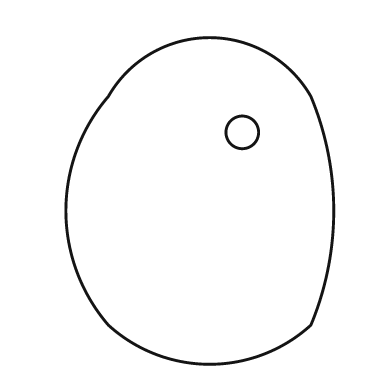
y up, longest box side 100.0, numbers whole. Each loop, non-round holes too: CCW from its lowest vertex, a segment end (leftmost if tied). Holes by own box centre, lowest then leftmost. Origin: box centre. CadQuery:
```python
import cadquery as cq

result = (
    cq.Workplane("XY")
    .moveTo(-28.0, -38.0)
    .threePointArc((3.0, -50.0), (34.0, -38.0))
    .threePointArc((41.0, -3.0), (34.0, 32.0))
    .threePointArc((3.0, 50.0), (-28.0, 32.0))
    .threePointArc((-41.0, -3.0), (-28.0, -38.0))
    .close()
    .moveTo(13.0, 21.0)
    .circle(5.0)
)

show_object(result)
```